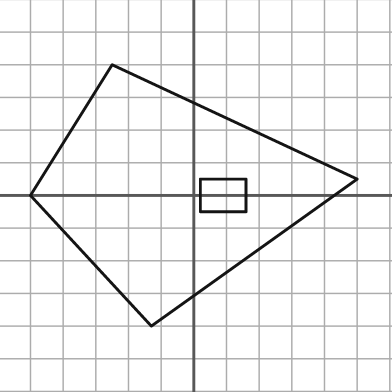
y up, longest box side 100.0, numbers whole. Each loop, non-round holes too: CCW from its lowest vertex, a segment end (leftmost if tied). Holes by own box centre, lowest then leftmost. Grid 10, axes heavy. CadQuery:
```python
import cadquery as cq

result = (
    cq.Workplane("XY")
    .moveTo(-13.0, -40.0)
    .lineTo(50.0, 5.0)
    .lineTo(-25.0, 40.0)
    .lineTo(-50.0, 0.0)
    .close()
    .moveTo(2.0, -5.0)
    .lineTo(16.0, -5.0)
    .lineTo(16.0, 5.0)
    .lineTo(2.0, 5.0)
    .close()
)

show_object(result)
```